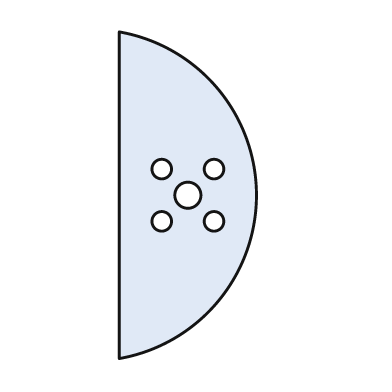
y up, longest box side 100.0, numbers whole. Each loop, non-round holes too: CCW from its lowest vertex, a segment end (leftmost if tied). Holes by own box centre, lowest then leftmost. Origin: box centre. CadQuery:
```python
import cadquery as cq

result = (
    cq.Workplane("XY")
    .moveTo(-21.0, -50.0)
    .threePointArc((21.0, 0.0), (-21.0, 50.0))
    .close()
    .moveTo(-8.0, -8.0)
    .circle(3.0)
    .moveTo(8.0, -8.0)
    .circle(3.0)
    .moveTo(0.0, 0.0)
    .circle(4.0)
    .moveTo(-8.0, 8.0)
    .circle(3.0)
    .moveTo(8.0, 8.0)
    .circle(3.0)
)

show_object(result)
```